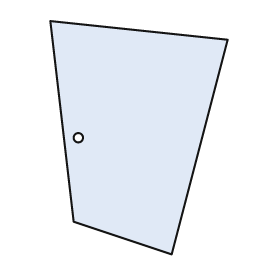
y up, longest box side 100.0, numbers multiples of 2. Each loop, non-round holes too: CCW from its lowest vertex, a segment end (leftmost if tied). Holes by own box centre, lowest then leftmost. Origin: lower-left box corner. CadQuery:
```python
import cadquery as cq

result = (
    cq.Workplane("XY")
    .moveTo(52.0, 0.0)
    .lineTo(76.0, 92.0)
    .lineTo(0.0, 100.0)
    .lineTo(10.0, 14.0)
    .close()
    .moveTo(12.0, 50.0)
    .circle(2.0)
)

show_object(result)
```